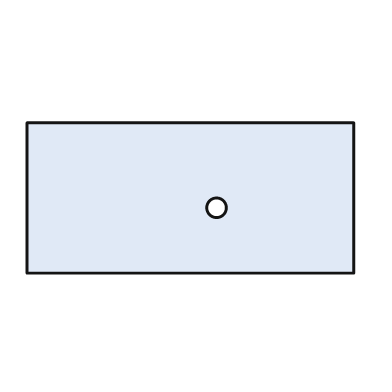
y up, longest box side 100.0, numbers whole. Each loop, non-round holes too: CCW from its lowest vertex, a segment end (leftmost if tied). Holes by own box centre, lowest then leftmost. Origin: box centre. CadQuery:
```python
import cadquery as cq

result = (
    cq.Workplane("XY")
    .moveTo(-50.0, -23.0)
    .lineTo(50.0, -23.0)
    .lineTo(50.0, 23.0)
    .lineTo(-50.0, 23.0)
    .close()
    .moveTo(8.0, -3.0)
    .circle(3.0)
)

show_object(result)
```